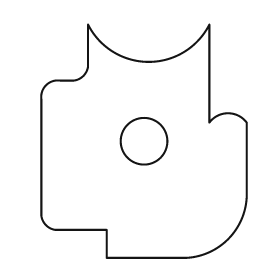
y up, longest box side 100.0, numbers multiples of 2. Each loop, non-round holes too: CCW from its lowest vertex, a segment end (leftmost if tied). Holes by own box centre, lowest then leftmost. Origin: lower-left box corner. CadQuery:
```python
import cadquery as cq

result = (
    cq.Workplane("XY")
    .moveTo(28.0, 0.0)
    .lineTo(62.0, 0.0)
    .threePointArc((80.0, 8.0), (88.0, 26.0))
    .lineTo(88.0, 58.0)
    .threePointArc((80.0, 62.0), (72.0, 58.0))
    .lineTo(72.0, 100.0)
    .threePointArc((46.0, 84.0), (20.0, 100.0))
    .lineTo(20.0, 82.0)
    .threePointArc((18.0, 78.0), (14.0, 76.0))
    .lineTo(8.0, 76.0)
    .threePointArc((2.0, 74.0), (0.0, 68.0))
    .lineTo(0.0, 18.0)
    .threePointArc((2.0, 14.0), (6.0, 12.0))
    .lineTo(28.0, 12.0)
    .close()
    .moveTo(44.0, 50.0)
    .circle(10.0)
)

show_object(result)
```